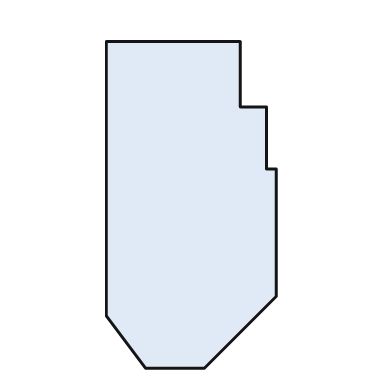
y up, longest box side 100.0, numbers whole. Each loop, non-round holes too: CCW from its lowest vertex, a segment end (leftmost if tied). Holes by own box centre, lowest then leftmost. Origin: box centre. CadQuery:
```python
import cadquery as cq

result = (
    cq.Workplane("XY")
    .moveTo(-14.0, -50.0)
    .lineTo(4.0, -50.0)
    .lineTo(26.0, -28.0)
    .lineTo(26.0, 11.0)
    .lineTo(23.0, 11.0)
    .lineTo(23.0, 30.0)
    .lineTo(15.0, 30.0)
    .lineTo(15.0, 50.0)
    .lineTo(-26.0, 50.0)
    .lineTo(-26.0, -34.0)
    .close()
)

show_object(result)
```